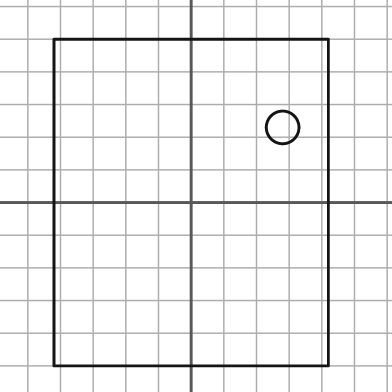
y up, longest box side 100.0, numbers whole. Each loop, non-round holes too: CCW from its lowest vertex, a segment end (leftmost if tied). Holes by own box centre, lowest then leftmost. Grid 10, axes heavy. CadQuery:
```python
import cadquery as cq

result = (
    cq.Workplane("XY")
    .moveTo(-42.0, -50.0)
    .lineTo(42.0, -50.0)
    .lineTo(42.0, 50.0)
    .lineTo(-42.0, 50.0)
    .close()
    .moveTo(28.0, 23.0)
    .circle(5.0)
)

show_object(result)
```